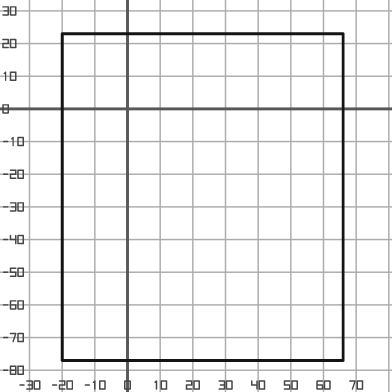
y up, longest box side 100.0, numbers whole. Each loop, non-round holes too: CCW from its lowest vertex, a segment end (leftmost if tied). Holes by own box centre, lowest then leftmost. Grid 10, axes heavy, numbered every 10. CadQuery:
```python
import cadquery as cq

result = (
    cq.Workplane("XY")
    .moveTo(-20.0, -77.0)
    .lineTo(66.0, -77.0)
    .lineTo(66.0, 23.0)
    .lineTo(-20.0, 23.0)
    .close()
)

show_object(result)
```